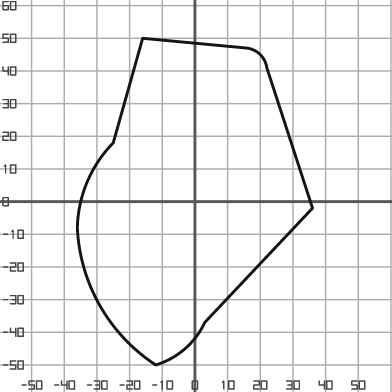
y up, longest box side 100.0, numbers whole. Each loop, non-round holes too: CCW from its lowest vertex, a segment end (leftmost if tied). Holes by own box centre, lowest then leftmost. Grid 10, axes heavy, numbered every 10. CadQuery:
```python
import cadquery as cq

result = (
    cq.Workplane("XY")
    .moveTo(-12.0, -50.0)
    .threePointArc((-3.0, -45.0), (3.0, -37.0))
    .lineTo(36.0, -2.0)
    .lineTo(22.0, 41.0)
    .threePointArc((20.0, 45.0), (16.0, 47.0))
    .lineTo(-16.0, 50.0)
    .lineTo(-25.0, 18.0)
    .threePointArc((-33.0, 6.0), (-36.0, -8.0))
    .threePointArc((-29.0, -32.0), (-12.0, -50.0))
    .close()
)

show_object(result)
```